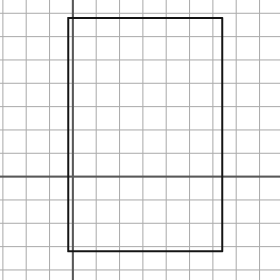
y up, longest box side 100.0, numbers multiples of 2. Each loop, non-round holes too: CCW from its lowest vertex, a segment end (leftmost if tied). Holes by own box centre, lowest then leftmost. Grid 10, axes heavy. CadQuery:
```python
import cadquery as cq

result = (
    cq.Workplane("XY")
    .moveTo(-2.0, -32.0)
    .lineTo(64.0, -32.0)
    .lineTo(64.0, 68.0)
    .lineTo(-2.0, 68.0)
    .close()
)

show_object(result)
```